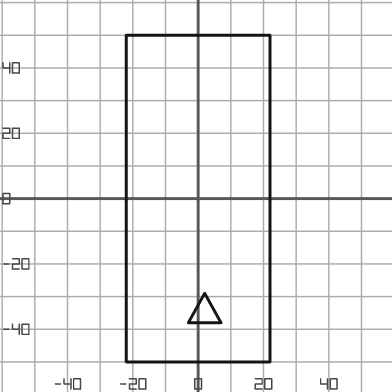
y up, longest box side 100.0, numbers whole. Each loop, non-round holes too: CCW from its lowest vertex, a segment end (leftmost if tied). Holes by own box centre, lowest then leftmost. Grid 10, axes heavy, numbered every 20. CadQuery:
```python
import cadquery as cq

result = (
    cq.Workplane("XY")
    .moveTo(-22.0, -50.0)
    .lineTo(22.0, -50.0)
    .lineTo(22.0, 50.0)
    .lineTo(-22.0, 50.0)
    .close()
    .moveTo(-3.0, -38.0)
    .lineTo(7.0, -38.0)
    .lineTo(2.0, -29.0)
    .close()
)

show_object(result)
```